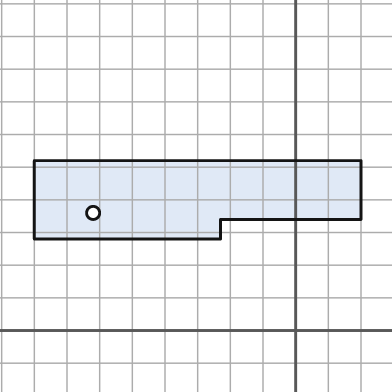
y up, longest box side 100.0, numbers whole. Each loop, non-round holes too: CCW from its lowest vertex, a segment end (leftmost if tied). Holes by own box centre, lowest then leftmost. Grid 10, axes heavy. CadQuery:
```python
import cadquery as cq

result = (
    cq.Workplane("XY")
    .moveTo(-80.0, 28.0)
    .lineTo(-23.0, 28.0)
    .lineTo(-23.0, 34.0)
    .lineTo(20.0, 34.0)
    .lineTo(20.0, 52.0)
    .lineTo(-80.0, 52.0)
    .close()
    .moveTo(-62.0, 36.0)
    .circle(2.0)
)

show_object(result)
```